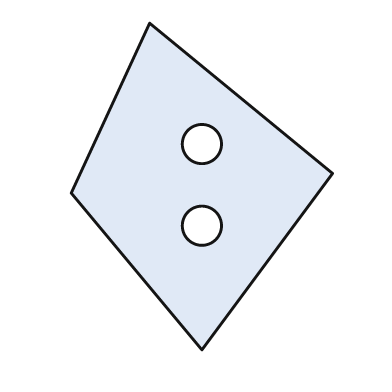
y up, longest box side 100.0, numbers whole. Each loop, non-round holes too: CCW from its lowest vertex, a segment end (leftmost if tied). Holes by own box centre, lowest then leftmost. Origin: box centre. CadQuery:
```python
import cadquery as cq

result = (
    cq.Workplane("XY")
    .moveTo(0.0, -50.0)
    .lineTo(40.0, 4.0)
    .lineTo(-16.0, 50.0)
    .lineTo(-40.0, -2.0)
    .close()
    .moveTo(0.0, -12.0)
    .circle(6.0)
    .moveTo(0.0, 13.0)
    .circle(6.0)
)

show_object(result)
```